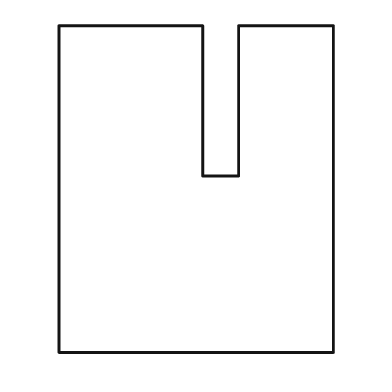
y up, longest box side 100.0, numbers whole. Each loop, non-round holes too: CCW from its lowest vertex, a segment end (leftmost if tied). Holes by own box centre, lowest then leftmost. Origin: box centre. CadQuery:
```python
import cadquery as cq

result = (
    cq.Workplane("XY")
    .moveTo(-42.0, -50.0)
    .lineTo(42.0, -50.0)
    .lineTo(42.0, 50.0)
    .lineTo(13.0, 50.0)
    .lineTo(13.0, 4.0)
    .lineTo(2.0, 4.0)
    .lineTo(2.0, 50.0)
    .lineTo(-42.0, 50.0)
    .close()
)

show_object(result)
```